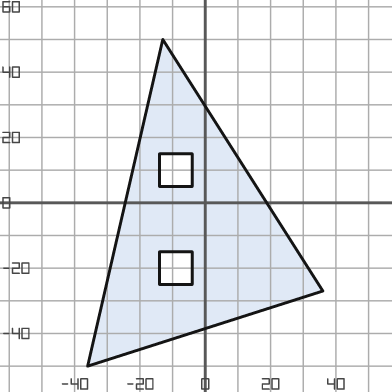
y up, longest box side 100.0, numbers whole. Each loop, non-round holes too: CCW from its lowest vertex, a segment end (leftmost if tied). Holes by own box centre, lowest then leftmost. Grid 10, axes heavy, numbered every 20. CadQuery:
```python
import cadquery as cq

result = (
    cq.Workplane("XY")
    .moveTo(-36.0, -50.0)
    .lineTo(36.0, -27.0)
    .lineTo(-13.0, 50.0)
    .close()
    .moveTo(-14.0, -25.0)
    .lineTo(-4.0, -25.0)
    .lineTo(-4.0, -15.0)
    .lineTo(-14.0, -15.0)
    .close()
    .moveTo(-14.0, 5.0)
    .lineTo(-4.0, 5.0)
    .lineTo(-4.0, 15.0)
    .lineTo(-14.0, 15.0)
    .close()
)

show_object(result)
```